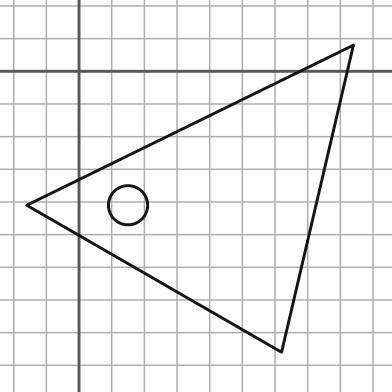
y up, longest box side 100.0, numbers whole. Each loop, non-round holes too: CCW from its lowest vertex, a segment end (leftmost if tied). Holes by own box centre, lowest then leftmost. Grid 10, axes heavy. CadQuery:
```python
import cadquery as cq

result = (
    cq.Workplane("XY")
    .moveTo(62.0, -86.0)
    .lineTo(84.0, 8.0)
    .lineTo(-16.0, -41.0)
    .close()
    .moveTo(15.0, -41.0)
    .circle(6.0)
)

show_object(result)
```